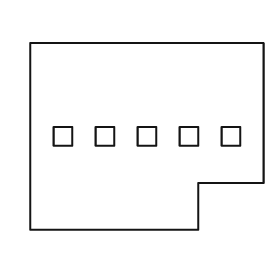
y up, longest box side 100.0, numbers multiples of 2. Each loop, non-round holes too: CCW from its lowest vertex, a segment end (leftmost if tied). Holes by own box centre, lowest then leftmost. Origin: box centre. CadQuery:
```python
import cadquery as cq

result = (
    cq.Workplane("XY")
    .moveTo(-50.0, -40.0)
    .lineTo(22.0, -40.0)
    .lineTo(22.0, -20.0)
    .lineTo(50.0, -20.0)
    .lineTo(50.0, 40.0)
    .lineTo(-50.0, 40.0)
    .close()
    .moveTo(-40.0, -4.0)
    .lineTo(-32.0, -4.0)
    .lineTo(-32.0, 4.0)
    .lineTo(-40.0, 4.0)
    .close()
    .moveTo(-22.0, -4.0)
    .lineTo(-14.0, -4.0)
    .lineTo(-14.0, 4.0)
    .lineTo(-22.0, 4.0)
    .close()
    .moveTo(-4.0, -4.0)
    .lineTo(4.0, -4.0)
    .lineTo(4.0, 4.0)
    .lineTo(-4.0, 4.0)
    .close()
    .moveTo(14.0, -4.0)
    .lineTo(22.0, -4.0)
    .lineTo(22.0, 4.0)
    .lineTo(14.0, 4.0)
    .close()
    .moveTo(32.0, -4.0)
    .lineTo(40.0, -4.0)
    .lineTo(40.0, 4.0)
    .lineTo(32.0, 4.0)
    .close()
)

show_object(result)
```